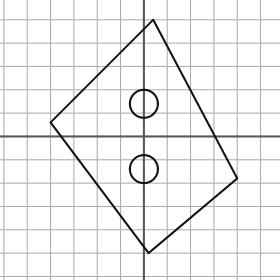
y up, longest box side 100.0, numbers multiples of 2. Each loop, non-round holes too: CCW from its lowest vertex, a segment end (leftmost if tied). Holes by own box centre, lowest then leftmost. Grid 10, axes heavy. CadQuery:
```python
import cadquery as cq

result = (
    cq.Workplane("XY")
    .moveTo(2.0, -50.0)
    .lineTo(40.0, -18.0)
    .lineTo(4.0, 50.0)
    .lineTo(-40.0, 6.0)
    .close()
    .moveTo(0.0, -14.0)
    .circle(6.0)
    .moveTo(0.0, 14.0)
    .circle(6.0)
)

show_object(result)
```